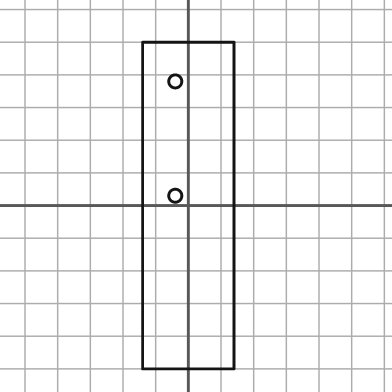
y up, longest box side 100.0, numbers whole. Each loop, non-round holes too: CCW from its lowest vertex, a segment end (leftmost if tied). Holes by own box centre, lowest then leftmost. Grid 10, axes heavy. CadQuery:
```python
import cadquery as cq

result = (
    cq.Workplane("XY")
    .moveTo(-14.0, -50.0)
    .lineTo(14.0, -50.0)
    .lineTo(14.0, 50.0)
    .lineTo(-14.0, 50.0)
    .close()
    .moveTo(-4.0, 3.0)
    .circle(2.0)
    .moveTo(-4.0, 38.0)
    .circle(2.0)
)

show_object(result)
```